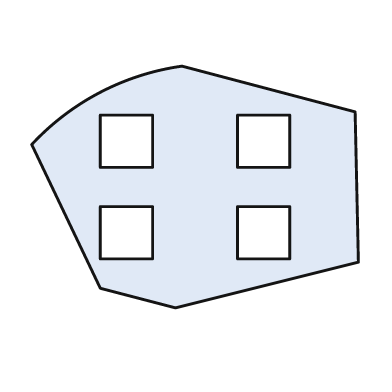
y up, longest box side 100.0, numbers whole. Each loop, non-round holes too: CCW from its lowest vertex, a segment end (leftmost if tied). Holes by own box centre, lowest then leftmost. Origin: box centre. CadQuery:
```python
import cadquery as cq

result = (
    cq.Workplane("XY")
    .moveTo(-6.0, -37.0)
    .lineTo(50.0, -23.0)
    .lineTo(49.0, 23.0)
    .lineTo(-4.0, 37.0)
    .threePointArc((-29.0, 29.0), (-50.0, 13.0))
    .lineTo(-29.0, -31.0)
    .close()
    .moveTo(-29.0, -22.0)
    .lineTo(-13.0, -22.0)
    .lineTo(-13.0, -6.0)
    .lineTo(-29.0, -6.0)
    .close()
    .moveTo(13.0, -22.0)
    .lineTo(29.0, -22.0)
    .lineTo(29.0, -6.0)
    .lineTo(13.0, -6.0)
    .close()
    .moveTo(-29.0, 6.0)
    .lineTo(-13.0, 6.0)
    .lineTo(-13.0, 22.0)
    .lineTo(-29.0, 22.0)
    .close()
    .moveTo(13.0, 6.0)
    .lineTo(29.0, 6.0)
    .lineTo(29.0, 22.0)
    .lineTo(13.0, 22.0)
    .close()
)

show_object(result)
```